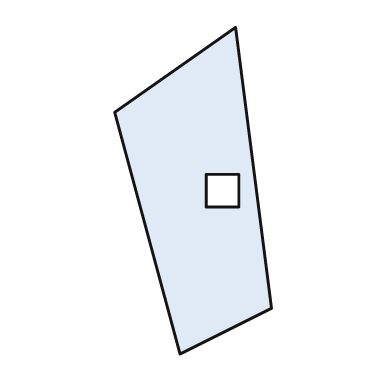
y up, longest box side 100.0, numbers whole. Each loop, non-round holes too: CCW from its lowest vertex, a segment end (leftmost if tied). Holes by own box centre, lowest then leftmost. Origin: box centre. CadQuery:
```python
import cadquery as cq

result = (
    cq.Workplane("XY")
    .moveTo(-4.0, -50.0)
    .lineTo(24.0, -36.0)
    .lineTo(13.0, 50.0)
    .lineTo(-24.0, 24.0)
    .close()
    .moveTo(4.0, -5.0)
    .lineTo(14.0, -5.0)
    .lineTo(14.0, 5.0)
    .lineTo(4.0, 5.0)
    .close()
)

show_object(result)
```